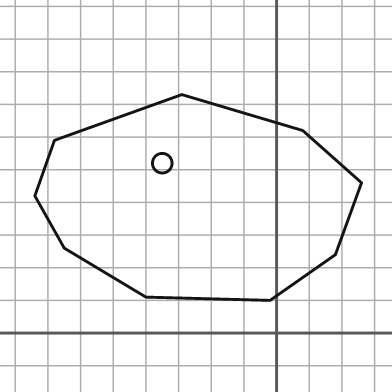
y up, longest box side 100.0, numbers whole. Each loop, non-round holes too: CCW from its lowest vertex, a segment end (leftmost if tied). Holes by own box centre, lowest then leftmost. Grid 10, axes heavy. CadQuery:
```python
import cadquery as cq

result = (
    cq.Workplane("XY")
    .moveTo(-2.0, 10.0)
    .lineTo(18.0, 24.0)
    .lineTo(26.0, 46.0)
    .lineTo(8.0, 62.0)
    .lineTo(-29.0, 73.0)
    .lineTo(-68.0, 59.0)
    .lineTo(-74.0, 42.0)
    .lineTo(-65.0, 26.0)
    .lineTo(-40.0, 11.0)
    .close()
    .moveTo(-35.0, 52.0)
    .circle(3.0)
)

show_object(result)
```